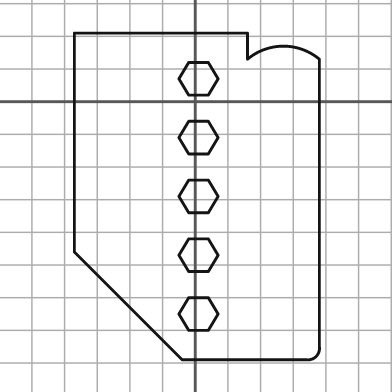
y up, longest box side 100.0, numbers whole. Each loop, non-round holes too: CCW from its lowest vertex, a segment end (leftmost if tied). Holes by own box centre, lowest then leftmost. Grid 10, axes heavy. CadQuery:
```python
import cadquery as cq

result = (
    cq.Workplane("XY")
    .moveTo(-4.0, -79.0)
    .lineTo(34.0, -79.0)
    .threePointArc((37.0, -78.0), (38.0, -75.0))
    .lineTo(38.0, 13.0)
    .threePointArc((27.0, 17.0), (16.0, 13.0))
    .lineTo(16.0, 21.0)
    .lineTo(-37.0, 21.0)
    .lineTo(-37.0, -46.0)
    .close()
    .moveTo(-2.0, -70.0)
    .lineTo(4.0, -70.0)
    .lineTo(7.0, -65.0)
    .lineTo(4.0, -60.0)
    .lineTo(-2.0, -60.0)
    .lineTo(-5.0, -65.0)
    .close()
    .moveTo(-2.0, -52.0)
    .lineTo(4.0, -52.0)
    .lineTo(7.0, -47.0)
    .lineTo(4.0, -42.0)
    .lineTo(-2.0, -42.0)
    .lineTo(-5.0, -47.0)
    .close()
    .moveTo(-2.0, -34.0)
    .lineTo(4.0, -34.0)
    .lineTo(7.0, -29.0)
    .lineTo(4.0, -24.0)
    .lineTo(-2.0, -24.0)
    .lineTo(-5.0, -29.0)
    .close()
    .moveTo(-2.0, -16.0)
    .lineTo(4.0, -16.0)
    .lineTo(7.0, -11.0)
    .lineTo(4.0, -6.0)
    .lineTo(-2.0, -6.0)
    .lineTo(-5.0, -11.0)
    .close()
    .moveTo(-2.0, 2.0)
    .lineTo(4.0, 2.0)
    .lineTo(7.0, 7.0)
    .lineTo(4.0, 12.0)
    .lineTo(-2.0, 12.0)
    .lineTo(-5.0, 7.0)
    .close()
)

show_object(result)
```